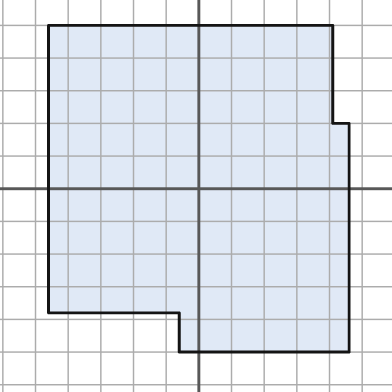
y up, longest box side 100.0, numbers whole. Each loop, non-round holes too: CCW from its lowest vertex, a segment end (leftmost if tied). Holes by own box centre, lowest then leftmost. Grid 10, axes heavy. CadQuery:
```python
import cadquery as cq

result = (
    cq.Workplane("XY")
    .moveTo(-6.0, -50.0)
    .lineTo(46.0, -50.0)
    .lineTo(46.0, 20.0)
    .lineTo(41.0, 20.0)
    .lineTo(41.0, 50.0)
    .lineTo(-46.0, 50.0)
    .lineTo(-46.0, -38.0)
    .lineTo(-6.0, -38.0)
    .close()
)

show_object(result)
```